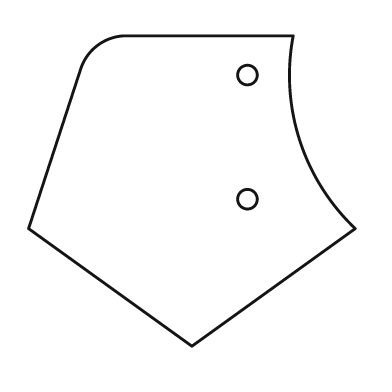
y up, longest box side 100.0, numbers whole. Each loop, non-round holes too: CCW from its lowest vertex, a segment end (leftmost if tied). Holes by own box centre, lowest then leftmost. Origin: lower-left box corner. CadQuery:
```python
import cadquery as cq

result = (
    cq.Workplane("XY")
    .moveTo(50.0, 0.0)
    .lineTo(100.0, 36.0)
    .threePointArc((83.0, 63.0), (81.0, 95.0))
    .lineTo(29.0, 95.0)
    .threePointArc((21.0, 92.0), (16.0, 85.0))
    .lineTo(0.0, 36.0)
    .close()
    .moveTo(67.0, 45.0)
    .circle(3.0)
    .moveTo(67.0, 83.0)
    .circle(3.0)
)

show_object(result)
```